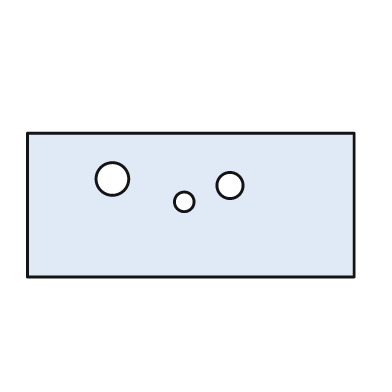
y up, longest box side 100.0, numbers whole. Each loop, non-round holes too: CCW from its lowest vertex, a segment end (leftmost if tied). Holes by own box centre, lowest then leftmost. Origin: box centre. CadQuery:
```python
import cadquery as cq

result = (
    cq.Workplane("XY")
    .moveTo(-50.0, -22.0)
    .lineTo(50.0, -22.0)
    .lineTo(50.0, 22.0)
    .lineTo(-50.0, 22.0)
    .close()
    .moveTo(-2.0, 1.0)
    .circle(3.0)
    .moveTo(12.0, 6.0)
    .circle(4.0)
    .moveTo(-24.0, 8.0)
    .circle(5.0)
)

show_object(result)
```